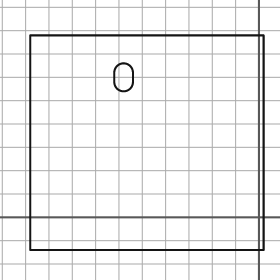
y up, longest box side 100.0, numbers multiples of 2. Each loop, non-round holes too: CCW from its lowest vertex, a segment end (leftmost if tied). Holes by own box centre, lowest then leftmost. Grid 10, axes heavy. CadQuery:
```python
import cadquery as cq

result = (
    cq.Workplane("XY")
    .moveTo(-98.0, -14.0)
    .lineTo(2.0, -14.0)
    .lineTo(2.0, 78.0)
    .lineTo(-98.0, 78.0)
    .close()
    .moveTo(-62.0, 58.0)
    .threePointArc((-58.0, 54.0), (-54.0, 58.0))
    .lineTo(-54.0, 62.0)
    .threePointArc((-58.0, 66.0), (-62.0, 62.0))
    .close()
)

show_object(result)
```